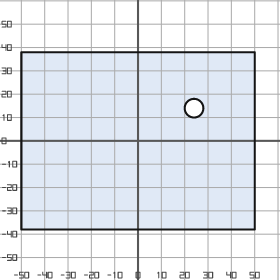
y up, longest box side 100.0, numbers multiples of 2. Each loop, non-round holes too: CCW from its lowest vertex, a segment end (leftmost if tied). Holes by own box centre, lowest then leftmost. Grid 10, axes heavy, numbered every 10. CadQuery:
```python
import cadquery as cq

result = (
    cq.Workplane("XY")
    .moveTo(-50.0, -38.0)
    .lineTo(50.0, -38.0)
    .lineTo(50.0, 38.0)
    .lineTo(-50.0, 38.0)
    .close()
    .moveTo(24.0, 14.0)
    .circle(4.0)
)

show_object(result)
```